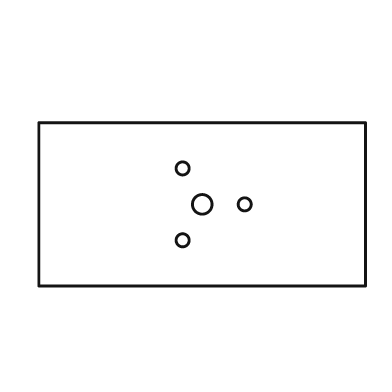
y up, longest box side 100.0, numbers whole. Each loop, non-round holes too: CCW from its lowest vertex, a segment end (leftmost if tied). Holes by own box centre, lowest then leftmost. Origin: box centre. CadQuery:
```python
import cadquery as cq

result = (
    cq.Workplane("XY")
    .moveTo(-50.0, -25.0)
    .lineTo(50.0, -25.0)
    .lineTo(50.0, 25.0)
    .lineTo(-50.0, 25.0)
    .close()
    .moveTo(-6.0, -11.0)
    .circle(2.0)
    .moveTo(0.0, 0.0)
    .circle(3.0)
    .moveTo(13.0, 0.0)
    .circle(2.0)
    .moveTo(-6.0, 11.0)
    .circle(2.0)
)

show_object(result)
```